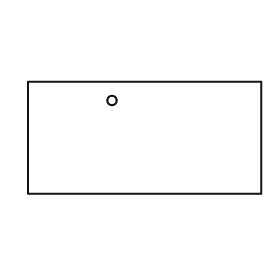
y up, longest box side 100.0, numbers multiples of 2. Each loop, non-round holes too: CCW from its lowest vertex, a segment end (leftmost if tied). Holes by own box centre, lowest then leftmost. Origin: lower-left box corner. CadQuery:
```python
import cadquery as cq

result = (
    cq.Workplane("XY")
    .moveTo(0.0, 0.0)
    .lineTo(100.0, 0.0)
    .lineTo(100.0, 48.0)
    .lineTo(0.0, 48.0)
    .close()
    .moveTo(36.0, 40.0)
    .circle(2.0)
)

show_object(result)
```